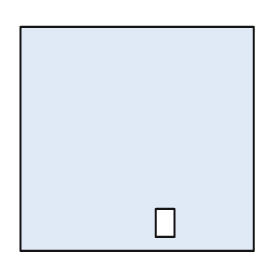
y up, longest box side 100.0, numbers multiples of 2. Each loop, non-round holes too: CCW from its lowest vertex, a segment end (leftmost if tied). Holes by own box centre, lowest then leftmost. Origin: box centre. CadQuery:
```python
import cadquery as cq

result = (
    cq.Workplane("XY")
    .moveTo(-50.0, -48.0)
    .lineTo(50.0, -48.0)
    .lineTo(50.0, 48.0)
    .lineTo(-50.0, 48.0)
    .close()
    .moveTo(8.0, -42.0)
    .lineTo(16.0, -42.0)
    .lineTo(16.0, -30.0)
    .lineTo(8.0, -30.0)
    .close()
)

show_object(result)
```